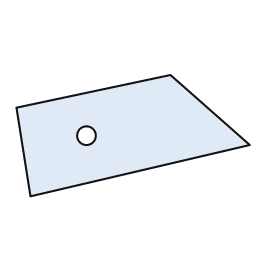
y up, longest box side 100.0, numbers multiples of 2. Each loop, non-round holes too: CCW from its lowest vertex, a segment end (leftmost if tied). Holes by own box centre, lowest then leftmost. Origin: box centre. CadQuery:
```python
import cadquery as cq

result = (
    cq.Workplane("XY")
    .moveTo(-44.0, -26.0)
    .lineTo(50.0, -4.0)
    .lineTo(16.0, 26.0)
    .lineTo(-50.0, 12.0)
    .close()
    .moveTo(-20.0, 0.0)
    .circle(4.0)
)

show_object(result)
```